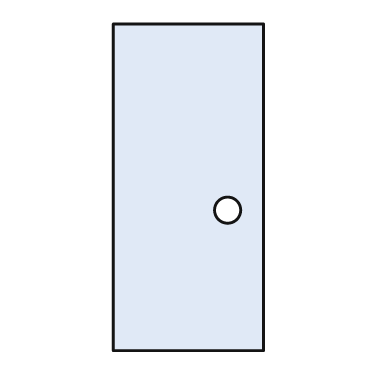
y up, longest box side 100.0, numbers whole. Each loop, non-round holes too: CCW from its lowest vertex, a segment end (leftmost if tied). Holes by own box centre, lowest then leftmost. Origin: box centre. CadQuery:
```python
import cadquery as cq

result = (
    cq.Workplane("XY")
    .moveTo(-23.0, -50.0)
    .lineTo(23.0, -50.0)
    .lineTo(23.0, 50.0)
    .lineTo(-23.0, 50.0)
    .close()
    .moveTo(12.0, -7.0)
    .circle(4.0)
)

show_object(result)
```